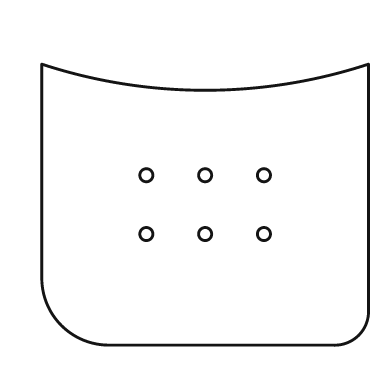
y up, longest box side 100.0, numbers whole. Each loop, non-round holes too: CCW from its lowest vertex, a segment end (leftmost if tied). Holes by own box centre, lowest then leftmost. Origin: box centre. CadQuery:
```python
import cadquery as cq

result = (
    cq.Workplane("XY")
    .moveTo(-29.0, -43.0)
    .lineTo(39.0, -43.0)
    .threePointArc((47.0, -40.0), (50.0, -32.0))
    .lineTo(50.0, 43.0)
    .threePointArc((0.0, 35.0), (-50.0, 43.0))
    .lineTo(-50.0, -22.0)
    .threePointArc((-44.0, -37.0), (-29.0, -43.0))
    .close()
    .moveTo(-18.0, -9.0)
    .circle(2.0)
    .moveTo(0.0, -9.0)
    .circle(2.0)
    .moveTo(18.0, -9.0)
    .circle(2.0)
    .moveTo(-18.0, 9.0)
    .circle(2.0)
    .moveTo(0.0, 9.0)
    .circle(2.0)
    .moveTo(18.0, 9.0)
    .circle(2.0)
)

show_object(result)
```